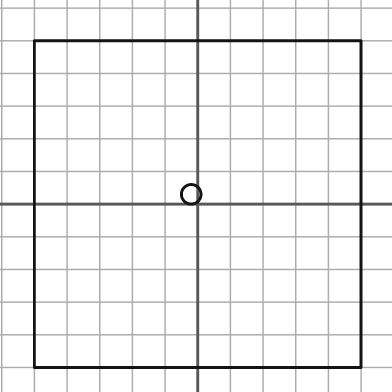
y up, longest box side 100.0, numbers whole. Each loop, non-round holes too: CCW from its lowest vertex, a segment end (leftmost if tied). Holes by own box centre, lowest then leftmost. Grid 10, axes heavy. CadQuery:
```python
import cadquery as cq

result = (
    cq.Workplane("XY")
    .moveTo(-50.0, -50.0)
    .lineTo(50.0, -50.0)
    .lineTo(50.0, 50.0)
    .lineTo(-50.0, 50.0)
    .close()
    .moveTo(-2.0, 3.0)
    .circle(3.0)
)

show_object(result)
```